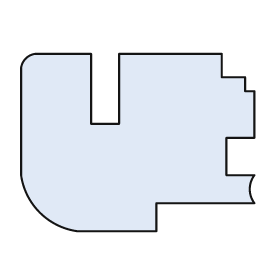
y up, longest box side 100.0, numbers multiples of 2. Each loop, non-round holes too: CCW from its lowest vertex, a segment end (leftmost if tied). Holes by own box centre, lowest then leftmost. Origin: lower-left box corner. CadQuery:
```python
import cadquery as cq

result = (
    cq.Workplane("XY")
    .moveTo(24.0, 0.0)
    .lineTo(58.0, 0.0)
    .lineTo(58.0, 12.0)
    .lineTo(100.0, 12.0)
    .threePointArc((98.0, 18.0), (100.0, 24.0))
    .lineTo(88.0, 24.0)
    .lineTo(88.0, 40.0)
    .lineTo(100.0, 40.0)
    .lineTo(100.0, 60.0)
    .lineTo(96.0, 60.0)
    .lineTo(96.0, 66.0)
    .lineTo(86.0, 66.0)
    .lineTo(86.0, 76.0)
    .lineTo(42.0, 76.0)
    .lineTo(42.0, 46.0)
    .lineTo(30.0, 46.0)
    .lineTo(30.0, 76.0)
    .lineTo(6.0, 76.0)
    .threePointArc((2.0, 74.0), (0.0, 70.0))
    .lineTo(0.0, 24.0)
    .threePointArc((8.0, 8.0), (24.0, 0.0))
    .close()
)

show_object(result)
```